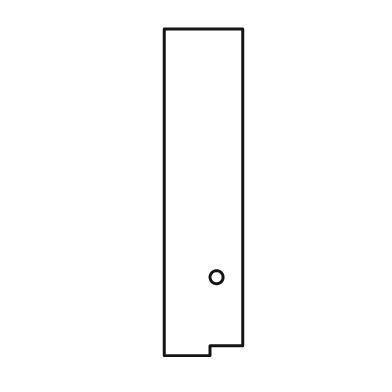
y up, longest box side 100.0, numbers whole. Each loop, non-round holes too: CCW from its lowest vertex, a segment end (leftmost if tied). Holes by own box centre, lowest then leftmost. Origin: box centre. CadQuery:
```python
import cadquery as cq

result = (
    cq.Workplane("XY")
    .moveTo(-12.0, -50.0)
    .lineTo(2.0, -50.0)
    .lineTo(2.0, -47.0)
    .lineTo(12.0, -47.0)
    .lineTo(12.0, 50.0)
    .lineTo(-12.0, 50.0)
    .close()
    .moveTo(4.0, -26.0)
    .circle(2.0)
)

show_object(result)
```